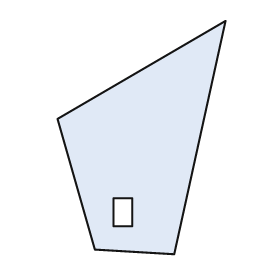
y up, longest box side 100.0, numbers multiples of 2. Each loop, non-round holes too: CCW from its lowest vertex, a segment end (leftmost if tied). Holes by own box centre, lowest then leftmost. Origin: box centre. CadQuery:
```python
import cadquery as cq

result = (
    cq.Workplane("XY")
    .moveTo(14.0, -50.0)
    .lineTo(36.0, 50.0)
    .lineTo(-36.0, 8.0)
    .lineTo(-20.0, -48.0)
    .close()
    .moveTo(-12.0, -38.0)
    .lineTo(-4.0, -38.0)
    .lineTo(-4.0, -26.0)
    .lineTo(-12.0, -26.0)
    .close()
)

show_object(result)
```